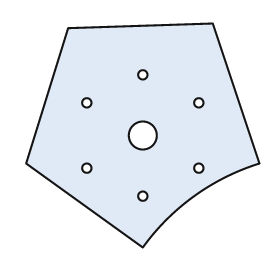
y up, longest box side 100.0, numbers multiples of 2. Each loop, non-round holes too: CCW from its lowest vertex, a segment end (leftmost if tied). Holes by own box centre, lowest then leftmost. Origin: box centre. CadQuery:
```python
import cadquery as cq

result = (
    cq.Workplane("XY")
    .moveTo(0.0, -48.0)
    .threePointArc((22.0, -26.0), (50.0, -12.0))
    .lineTo(30.0, 48.0)
    .lineTo(-32.0, 46.0)
    .lineTo(-50.0, -12.0)
    .close()
    .moveTo(0.0, -26.0)
    .circle(2.0)
    .moveTo(-24.0, -14.0)
    .circle(2.0)
    .moveTo(24.0, -14.0)
    .circle(2.0)
    .moveTo(0.0, 0.0)
    .circle(6.0)
    .moveTo(-24.0, 14.0)
    .circle(2.0)
    .moveTo(24.0, 14.0)
    .circle(2.0)
    .moveTo(0.0, 26.0)
    .circle(2.0)
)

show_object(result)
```